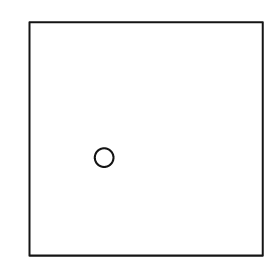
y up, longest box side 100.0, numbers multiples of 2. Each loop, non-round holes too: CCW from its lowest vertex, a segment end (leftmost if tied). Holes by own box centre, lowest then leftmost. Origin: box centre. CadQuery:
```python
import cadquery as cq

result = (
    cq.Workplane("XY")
    .moveTo(-50.0, -50.0)
    .lineTo(50.0, -50.0)
    .lineTo(50.0, 50.0)
    .lineTo(-50.0, 50.0)
    .close()
    .moveTo(-18.0, -8.0)
    .circle(4.0)
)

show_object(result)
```